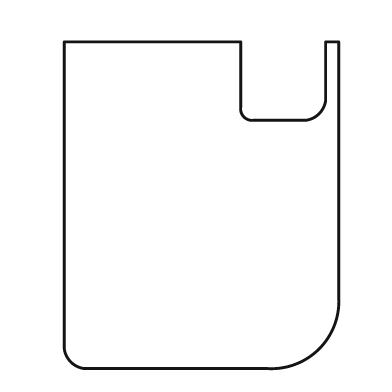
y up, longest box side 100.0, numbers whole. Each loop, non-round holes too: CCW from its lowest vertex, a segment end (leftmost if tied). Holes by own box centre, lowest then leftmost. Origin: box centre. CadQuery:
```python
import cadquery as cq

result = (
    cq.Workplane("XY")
    .moveTo(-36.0, -50.0)
    .lineTo(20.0, -50.0)
    .threePointArc((36.0, -44.0), (42.0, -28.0))
    .lineTo(42.0, 50.0)
    .lineTo(38.0, 50.0)
    .lineTo(38.0, 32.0)
    .threePointArc((36.0, 28.0), (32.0, 26.0))
    .lineTo(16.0, 26.0)
    .threePointArc((13.0, 27.0), (12.0, 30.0))
    .lineTo(12.0, 50.0)
    .lineTo(-42.0, 50.0)
    .lineTo(-42.0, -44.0)
    .threePointArc((-40.0, -48.0), (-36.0, -50.0))
    .close()
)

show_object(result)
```